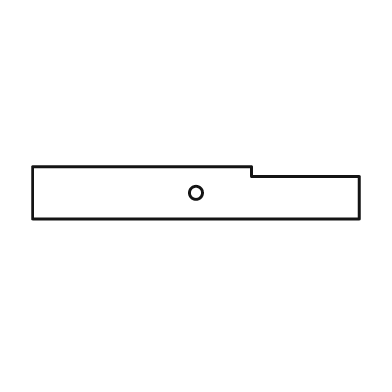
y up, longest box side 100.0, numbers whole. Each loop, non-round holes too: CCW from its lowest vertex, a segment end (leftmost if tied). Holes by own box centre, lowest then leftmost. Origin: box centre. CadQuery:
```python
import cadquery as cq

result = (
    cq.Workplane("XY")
    .moveTo(-50.0, -8.0)
    .lineTo(50.0, -8.0)
    .lineTo(50.0, 5.0)
    .lineTo(17.0, 5.0)
    .lineTo(17.0, 8.0)
    .lineTo(-50.0, 8.0)
    .close()
    .moveTo(0.0, 0.0)
    .circle(2.0)
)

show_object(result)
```